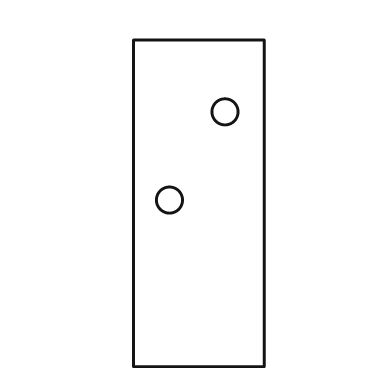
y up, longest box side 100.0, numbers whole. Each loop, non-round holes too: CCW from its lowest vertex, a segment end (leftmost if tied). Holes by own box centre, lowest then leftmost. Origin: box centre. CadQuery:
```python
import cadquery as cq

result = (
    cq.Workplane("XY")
    .moveTo(-20.0, -50.0)
    .lineTo(20.0, -50.0)
    .lineTo(20.0, 50.0)
    .lineTo(-20.0, 50.0)
    .close()
    .moveTo(-9.0, 1.0)
    .circle(4.0)
    .moveTo(8.0, 28.0)
    .circle(4.0)
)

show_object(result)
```